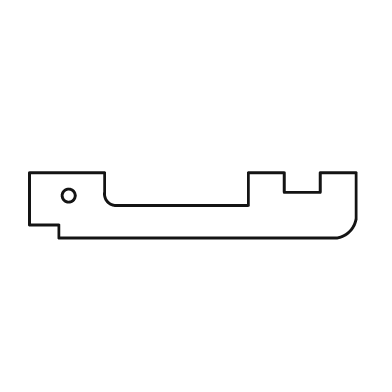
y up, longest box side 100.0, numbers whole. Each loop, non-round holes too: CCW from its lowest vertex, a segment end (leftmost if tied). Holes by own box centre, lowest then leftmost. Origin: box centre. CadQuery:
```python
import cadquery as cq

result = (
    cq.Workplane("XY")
    .moveTo(-41.0, -10.0)
    .lineTo(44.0, -10.0)
    .threePointArc((48.0, -8.0), (50.0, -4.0))
    .lineTo(50.0, 10.0)
    .lineTo(39.0, 10.0)
    .lineTo(39.0, 4.0)
    .lineTo(28.0, 4.0)
    .lineTo(28.0, 10.0)
    .lineTo(17.0, 10.0)
    .lineTo(17.0, 0.0)
    .lineTo(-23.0, 0.0)
    .threePointArc((-26.0, 1.0), (-27.0, 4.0))
    .lineTo(-27.0, 10.0)
    .lineTo(-50.0, 10.0)
    .lineTo(-50.0, -6.0)
    .lineTo(-41.0, -6.0)
    .close()
    .moveTo(-38.0, 3.0)
    .circle(2.0)
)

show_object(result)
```